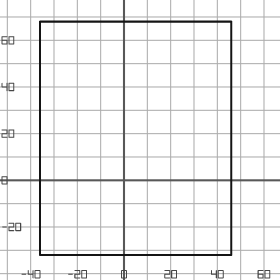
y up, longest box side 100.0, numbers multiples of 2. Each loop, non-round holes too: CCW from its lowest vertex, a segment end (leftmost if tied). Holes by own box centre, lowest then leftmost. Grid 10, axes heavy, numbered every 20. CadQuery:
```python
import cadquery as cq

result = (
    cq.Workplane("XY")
    .moveTo(-36.0, -32.0)
    .lineTo(46.0, -32.0)
    .lineTo(46.0, 68.0)
    .lineTo(-36.0, 68.0)
    .close()
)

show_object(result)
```